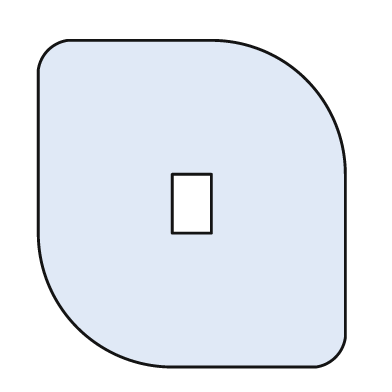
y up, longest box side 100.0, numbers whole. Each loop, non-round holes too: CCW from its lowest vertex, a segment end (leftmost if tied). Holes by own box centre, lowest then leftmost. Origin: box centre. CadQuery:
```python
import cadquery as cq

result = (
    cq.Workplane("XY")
    .moveTo(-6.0, -50.0)
    .lineTo(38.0, -50.0)
    .threePointArc((44.0, -47.0), (47.0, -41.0))
    .lineTo(47.0, 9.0)
    .threePointArc((35.0, 38.0), (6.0, 50.0))
    .lineTo(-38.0, 50.0)
    .threePointArc((-44.0, 47.0), (-47.0, 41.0))
    .lineTo(-47.0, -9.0)
    .threePointArc((-35.0, -38.0), (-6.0, -50.0))
    .close()
    .moveTo(-6.0, -9.0)
    .lineTo(6.0, -9.0)
    .lineTo(6.0, 9.0)
    .lineTo(-6.0, 9.0)
    .close()
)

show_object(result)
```